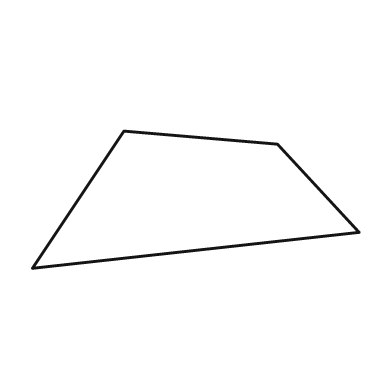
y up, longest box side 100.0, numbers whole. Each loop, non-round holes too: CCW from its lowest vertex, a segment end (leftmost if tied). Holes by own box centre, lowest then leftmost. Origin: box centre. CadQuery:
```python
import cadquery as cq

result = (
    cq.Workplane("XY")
    .moveTo(-50.0, -21.0)
    .lineTo(50.0, -10.0)
    .lineTo(25.0, 17.0)
    .lineTo(-22.0, 21.0)
    .close()
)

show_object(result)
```